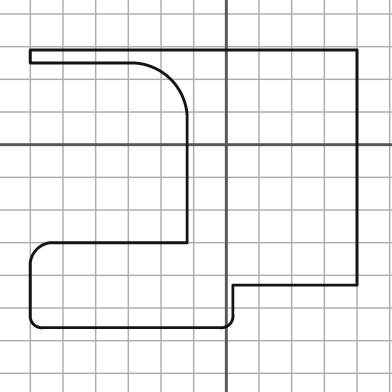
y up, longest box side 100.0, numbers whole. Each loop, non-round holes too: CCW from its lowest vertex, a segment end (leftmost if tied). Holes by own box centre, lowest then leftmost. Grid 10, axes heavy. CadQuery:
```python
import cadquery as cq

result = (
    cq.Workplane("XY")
    .moveTo(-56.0, -56.0)
    .lineTo(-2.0, -56.0)
    .threePointArc((1.0, -55.0), (2.0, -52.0))
    .lineTo(2.0, -43.0)
    .lineTo(40.0, -43.0)
    .lineTo(40.0, 29.0)
    .lineTo(-60.0, 29.0)
    .lineTo(-60.0, 25.0)
    .lineTo(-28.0, 25.0)
    .threePointArc((-17.0, 20.0), (-12.0, 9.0))
    .lineTo(-12.0, -30.0)
    .lineTo(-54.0, -30.0)
    .threePointArc((-58.0, -32.0), (-60.0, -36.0))
    .lineTo(-60.0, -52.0)
    .threePointArc((-59.0, -55.0), (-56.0, -56.0))
    .close()
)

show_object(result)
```